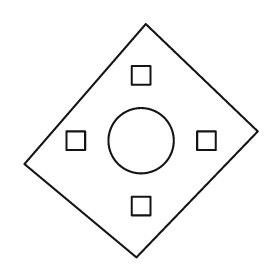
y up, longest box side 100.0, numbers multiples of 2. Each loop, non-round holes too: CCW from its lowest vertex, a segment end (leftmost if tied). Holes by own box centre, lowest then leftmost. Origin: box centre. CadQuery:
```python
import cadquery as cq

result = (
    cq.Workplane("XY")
    .moveTo(-2.0, -50.0)
    .lineTo(50.0, 4.0)
    .lineTo(2.0, 50.0)
    .lineTo(-50.0, -10.0)
    .close()
    .moveTo(-4.0, -32.0)
    .lineTo(4.0, -32.0)
    .lineTo(4.0, -24.0)
    .lineTo(-4.0, -24.0)
    .close()
    .moveTo(-32.0, -4.0)
    .lineTo(-24.0, -4.0)
    .lineTo(-24.0, 4.0)
    .lineTo(-32.0, 4.0)
    .close()
    .moveTo(0.0, 0.0)
    .circle(14.0)
    .moveTo(24.0, -4.0)
    .lineTo(32.0, -4.0)
    .lineTo(32.0, 4.0)
    .lineTo(24.0, 4.0)
    .close()
    .moveTo(-4.0, 24.0)
    .lineTo(4.0, 24.0)
    .lineTo(4.0, 32.0)
    .lineTo(-4.0, 32.0)
    .close()
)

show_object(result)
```